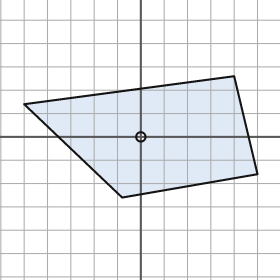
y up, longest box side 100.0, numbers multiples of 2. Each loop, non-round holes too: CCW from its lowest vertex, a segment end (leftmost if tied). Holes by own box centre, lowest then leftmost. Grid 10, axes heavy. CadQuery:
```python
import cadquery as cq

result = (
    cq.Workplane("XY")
    .moveTo(-8.0, -26.0)
    .lineTo(50.0, -16.0)
    .lineTo(40.0, 26.0)
    .lineTo(-50.0, 14.0)
    .close()
    .moveTo(0.0, 0.0)
    .circle(2.0)
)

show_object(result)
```